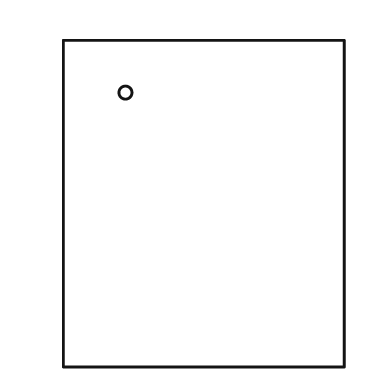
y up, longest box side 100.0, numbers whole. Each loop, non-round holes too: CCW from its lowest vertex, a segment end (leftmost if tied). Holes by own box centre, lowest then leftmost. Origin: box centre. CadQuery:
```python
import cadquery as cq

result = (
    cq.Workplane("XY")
    .moveTo(-43.0, -50.0)
    .lineTo(43.0, -50.0)
    .lineTo(43.0, 50.0)
    .lineTo(-43.0, 50.0)
    .close()
    .moveTo(-24.0, 34.0)
    .circle(2.0)
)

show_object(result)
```